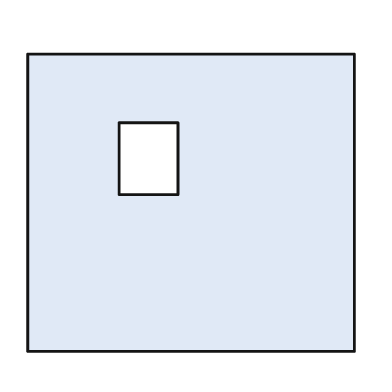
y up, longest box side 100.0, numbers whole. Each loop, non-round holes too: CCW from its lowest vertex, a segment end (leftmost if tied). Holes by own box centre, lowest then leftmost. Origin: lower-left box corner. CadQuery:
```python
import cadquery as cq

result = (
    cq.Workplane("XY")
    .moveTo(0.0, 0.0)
    .lineTo(100.0, 0.0)
    .lineTo(100.0, 91.0)
    .lineTo(0.0, 91.0)
    .close()
    .moveTo(28.0, 48.0)
    .lineTo(46.0, 48.0)
    .lineTo(46.0, 70.0)
    .lineTo(28.0, 70.0)
    .close()
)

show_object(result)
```